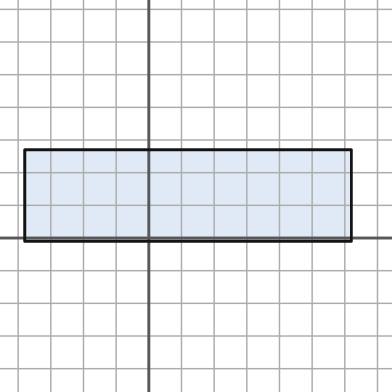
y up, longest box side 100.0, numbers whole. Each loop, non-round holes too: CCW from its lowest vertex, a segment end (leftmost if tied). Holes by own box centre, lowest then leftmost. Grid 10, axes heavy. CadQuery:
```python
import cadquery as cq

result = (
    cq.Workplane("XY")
    .moveTo(-38.0, -1.0)
    .lineTo(62.0, -1.0)
    .lineTo(62.0, 27.0)
    .lineTo(-38.0, 27.0)
    .close()
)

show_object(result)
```